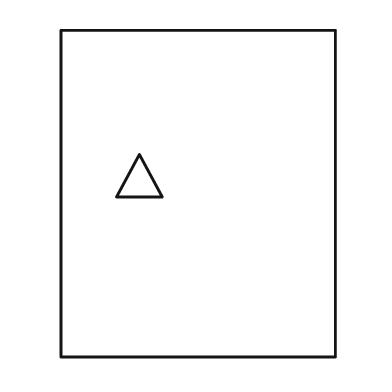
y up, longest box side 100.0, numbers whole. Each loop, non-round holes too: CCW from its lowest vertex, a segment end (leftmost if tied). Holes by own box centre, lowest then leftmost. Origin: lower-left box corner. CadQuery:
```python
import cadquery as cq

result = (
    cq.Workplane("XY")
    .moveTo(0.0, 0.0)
    .lineTo(84.0, 0.0)
    .lineTo(84.0, 100.0)
    .lineTo(0.0, 100.0)
    .close()
    .moveTo(17.0, 49.0)
    .lineTo(31.0, 49.0)
    .lineTo(24.0, 62.0)
    .close()
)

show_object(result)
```